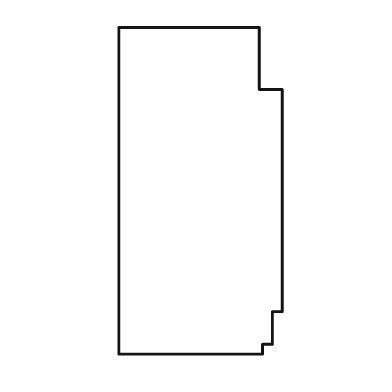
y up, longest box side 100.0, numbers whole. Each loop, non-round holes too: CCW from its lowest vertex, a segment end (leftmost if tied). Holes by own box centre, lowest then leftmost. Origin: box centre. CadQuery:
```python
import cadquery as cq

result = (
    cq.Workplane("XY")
    .moveTo(-25.0, -50.0)
    .lineTo(19.0, -50.0)
    .lineTo(19.0, -47.0)
    .lineTo(22.0, -47.0)
    .lineTo(22.0, -37.0)
    .lineTo(25.0, -37.0)
    .lineTo(25.0, 31.0)
    .lineTo(18.0, 31.0)
    .lineTo(18.0, 50.0)
    .lineTo(-25.0, 50.0)
    .close()
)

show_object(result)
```